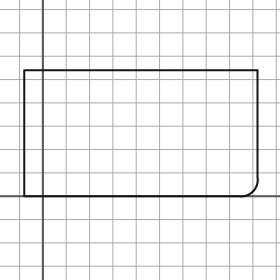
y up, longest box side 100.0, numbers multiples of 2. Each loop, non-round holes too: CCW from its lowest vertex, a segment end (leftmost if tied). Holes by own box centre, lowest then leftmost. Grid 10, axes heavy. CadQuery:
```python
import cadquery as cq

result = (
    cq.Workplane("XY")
    .moveTo(-8.0, 0.0)
    .lineTo(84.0, 0.0)
    .threePointArc((90.0, 2.0), (92.0, 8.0))
    .lineTo(92.0, 54.0)
    .lineTo(-8.0, 54.0)
    .close()
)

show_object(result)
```